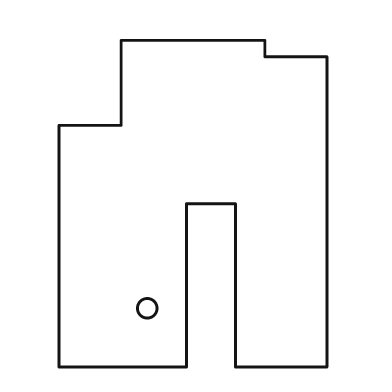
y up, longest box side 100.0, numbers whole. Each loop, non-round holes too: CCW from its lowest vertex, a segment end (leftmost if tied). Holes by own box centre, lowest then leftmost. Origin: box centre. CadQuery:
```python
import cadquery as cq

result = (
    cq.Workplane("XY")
    .moveTo(-41.0, -50.0)
    .lineTo(-2.0, -50.0)
    .lineTo(-2.0, 0.0)
    .lineTo(13.0, 0.0)
    .lineTo(13.0, -50.0)
    .lineTo(41.0, -50.0)
    .lineTo(41.0, 45.0)
    .lineTo(22.0, 45.0)
    .lineTo(22.0, 50.0)
    .lineTo(-22.0, 50.0)
    .lineTo(-22.0, 24.0)
    .lineTo(-41.0, 24.0)
    .close()
    .moveTo(-14.0, -32.0)
    .circle(3.0)
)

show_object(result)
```